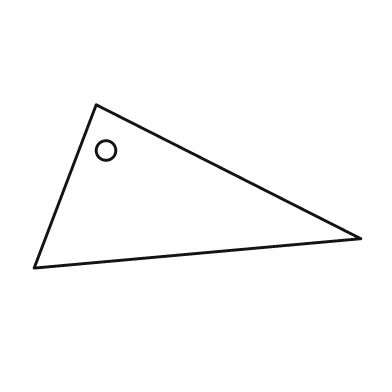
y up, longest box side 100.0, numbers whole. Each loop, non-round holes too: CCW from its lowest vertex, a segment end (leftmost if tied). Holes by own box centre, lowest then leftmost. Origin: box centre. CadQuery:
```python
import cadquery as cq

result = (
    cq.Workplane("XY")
    .moveTo(-50.0, -25.0)
    .lineTo(50.0, -16.0)
    .lineTo(-31.0, 25.0)
    .close()
    .moveTo(-28.0, 11.0)
    .circle(3.0)
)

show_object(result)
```